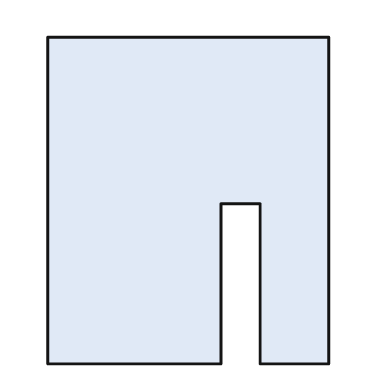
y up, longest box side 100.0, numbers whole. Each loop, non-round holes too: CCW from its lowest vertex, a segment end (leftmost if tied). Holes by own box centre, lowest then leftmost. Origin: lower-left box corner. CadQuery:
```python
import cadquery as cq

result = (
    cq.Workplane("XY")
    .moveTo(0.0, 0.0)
    .lineTo(53.0, 0.0)
    .lineTo(53.0, 49.0)
    .lineTo(65.0, 49.0)
    .lineTo(65.0, 0.0)
    .lineTo(86.0, 0.0)
    .lineTo(86.0, 100.0)
    .lineTo(0.0, 100.0)
    .close()
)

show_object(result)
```